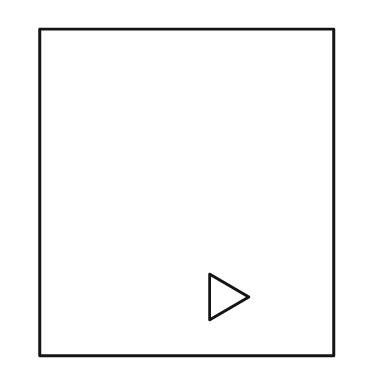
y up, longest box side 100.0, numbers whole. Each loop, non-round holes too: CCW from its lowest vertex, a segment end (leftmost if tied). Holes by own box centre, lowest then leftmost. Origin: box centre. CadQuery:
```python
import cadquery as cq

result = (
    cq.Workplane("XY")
    .moveTo(-45.0, -50.0)
    .lineTo(45.0, -50.0)
    .lineTo(45.0, 50.0)
    .lineTo(-45.0, 50.0)
    .close()
    .moveTo(7.0, -39.0)
    .lineTo(19.0, -32.0)
    .lineTo(7.0, -25.0)
    .close()
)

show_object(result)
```